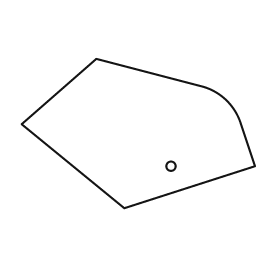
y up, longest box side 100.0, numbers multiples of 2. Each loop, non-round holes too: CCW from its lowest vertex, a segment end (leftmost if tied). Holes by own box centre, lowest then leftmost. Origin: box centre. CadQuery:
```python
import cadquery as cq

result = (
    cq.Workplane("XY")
    .moveTo(-6.0, -32.0)
    .lineTo(50.0, -14.0)
    .lineTo(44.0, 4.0)
    .threePointArc((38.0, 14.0), (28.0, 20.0))
    .lineTo(-18.0, 32.0)
    .lineTo(-50.0, 4.0)
    .close()
    .moveTo(14.0, -14.0)
    .circle(2.0)
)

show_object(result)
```